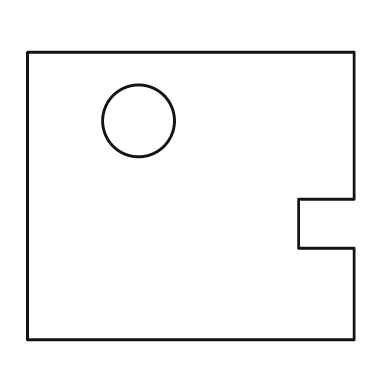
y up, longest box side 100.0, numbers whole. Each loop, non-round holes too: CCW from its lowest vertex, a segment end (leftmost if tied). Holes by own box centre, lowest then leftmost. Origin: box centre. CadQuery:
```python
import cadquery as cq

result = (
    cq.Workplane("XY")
    .moveTo(-50.0, -44.0)
    .lineTo(50.0, -44.0)
    .lineTo(50.0, -16.0)
    .lineTo(33.0, -16.0)
    .lineTo(33.0, -1.0)
    .lineTo(50.0, -1.0)
    .lineTo(50.0, 44.0)
    .lineTo(-50.0, 44.0)
    .close()
    .moveTo(-16.0, 23.0)
    .circle(11.0)
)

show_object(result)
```